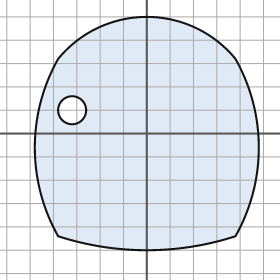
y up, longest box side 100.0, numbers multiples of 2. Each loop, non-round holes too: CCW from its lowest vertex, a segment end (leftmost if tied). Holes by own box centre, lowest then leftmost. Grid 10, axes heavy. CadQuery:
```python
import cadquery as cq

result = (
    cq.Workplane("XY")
    .moveTo(-38.0, -44.0)
    .threePointArc((0.0, -50.0), (38.0, -44.0))
    .threePointArc((48.0, -6.0), (38.0, 32.0))
    .threePointArc((0.0, 50.0), (-38.0, 32.0))
    .threePointArc((-48.0, -6.0), (-38.0, -44.0))
    .close()
    .moveTo(-32.0, 10.0)
    .circle(6.0)
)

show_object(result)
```